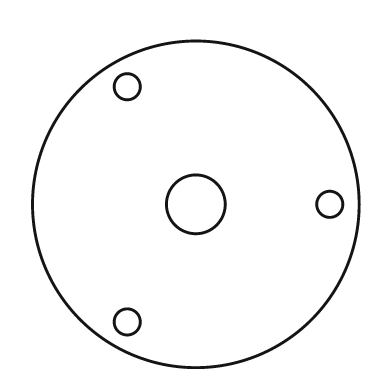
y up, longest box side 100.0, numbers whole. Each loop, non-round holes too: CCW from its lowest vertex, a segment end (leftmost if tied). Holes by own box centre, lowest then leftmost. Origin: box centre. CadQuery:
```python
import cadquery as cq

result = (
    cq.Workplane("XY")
    .moveTo(0.0, 0.0)
    .circle(50.0)
    .moveTo(-21.0, -36.0)
    .circle(4.0)
    .moveTo(0.0, 0.0)
    .circle(9.0)
    .moveTo(41.0, 0.0)
    .circle(4.0)
    .moveTo(-21.0, 36.0)
    .circle(4.0)
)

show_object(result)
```